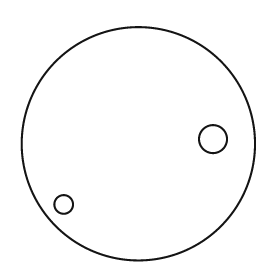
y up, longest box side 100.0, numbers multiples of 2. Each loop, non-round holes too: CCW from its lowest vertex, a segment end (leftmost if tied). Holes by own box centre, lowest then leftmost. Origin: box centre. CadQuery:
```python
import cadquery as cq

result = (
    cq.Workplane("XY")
    .moveTo(0.0, 0.0)
    .circle(50.0)
    .moveTo(-32.0, -26.0)
    .circle(4.0)
    .moveTo(32.0, 2.0)
    .circle(6.0)
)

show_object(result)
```